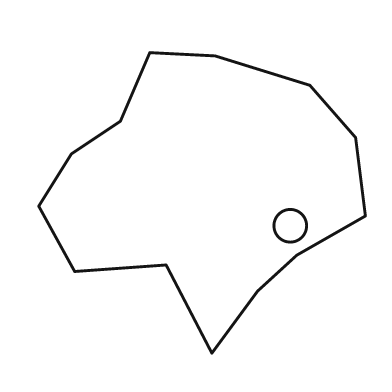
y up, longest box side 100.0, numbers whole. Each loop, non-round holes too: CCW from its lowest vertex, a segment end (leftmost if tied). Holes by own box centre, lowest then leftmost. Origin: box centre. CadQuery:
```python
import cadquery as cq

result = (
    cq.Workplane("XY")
    .moveTo(3.0, -46.0)
    .lineTo(17.0, -27.0)
    .lineTo(29.0, -16.0)
    .lineTo(50.0, -4.0)
    .lineTo(47.0, 20.0)
    .lineTo(33.0, 36.0)
    .lineTo(4.0, 45.0)
    .lineTo(-16.0, 46.0)
    .lineTo(-25.0, 25.0)
    .lineTo(-40.0, 15.0)
    .lineTo(-50.0, -1.0)
    .lineTo(-39.0, -21.0)
    .lineTo(-11.0, -19.0)
    .close()
    .moveTo(27.0, -7.0)
    .circle(5.0)
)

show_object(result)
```